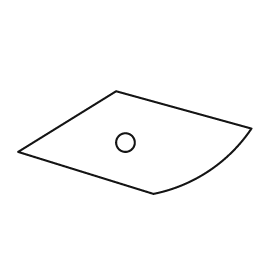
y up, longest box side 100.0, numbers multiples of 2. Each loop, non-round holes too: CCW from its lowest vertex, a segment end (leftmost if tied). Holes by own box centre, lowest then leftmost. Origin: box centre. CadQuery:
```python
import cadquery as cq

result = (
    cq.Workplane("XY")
    .moveTo(8.0, -22.0)
    .threePointArc((32.0, -12.0), (50.0, 6.0))
    .lineTo(-8.0, 22.0)
    .lineTo(-50.0, -4.0)
    .close()
    .moveTo(-4.0, 0.0)
    .circle(4.0)
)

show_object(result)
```